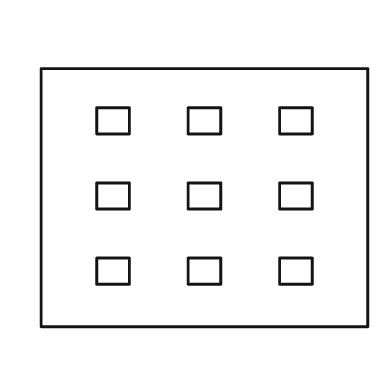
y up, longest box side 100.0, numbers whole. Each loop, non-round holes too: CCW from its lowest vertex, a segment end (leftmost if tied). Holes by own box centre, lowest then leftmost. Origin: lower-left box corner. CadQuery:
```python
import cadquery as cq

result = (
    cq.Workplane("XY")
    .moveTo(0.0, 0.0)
    .lineTo(100.0, 0.0)
    .lineTo(100.0, 79.0)
    .lineTo(0.0, 79.0)
    .close()
    .moveTo(17.0, 13.0)
    .lineTo(27.0, 13.0)
    .lineTo(27.0, 21.0)
    .lineTo(17.0, 21.0)
    .close()
    .moveTo(45.0, 13.0)
    .lineTo(55.0, 13.0)
    .lineTo(55.0, 21.0)
    .lineTo(45.0, 21.0)
    .close()
    .moveTo(73.0, 13.0)
    .lineTo(83.0, 13.0)
    .lineTo(83.0, 21.0)
    .lineTo(73.0, 21.0)
    .close()
    .moveTo(17.0, 36.0)
    .lineTo(27.0, 36.0)
    .lineTo(27.0, 44.0)
    .lineTo(17.0, 44.0)
    .close()
    .moveTo(45.0, 36.0)
    .lineTo(55.0, 36.0)
    .lineTo(55.0, 44.0)
    .lineTo(45.0, 44.0)
    .close()
    .moveTo(73.0, 36.0)
    .lineTo(83.0, 36.0)
    .lineTo(83.0, 44.0)
    .lineTo(73.0, 44.0)
    .close()
    .moveTo(17.0, 59.0)
    .lineTo(27.0, 59.0)
    .lineTo(27.0, 67.0)
    .lineTo(17.0, 67.0)
    .close()
    .moveTo(45.0, 59.0)
    .lineTo(55.0, 59.0)
    .lineTo(55.0, 67.0)
    .lineTo(45.0, 67.0)
    .close()
    .moveTo(73.0, 59.0)
    .lineTo(83.0, 59.0)
    .lineTo(83.0, 67.0)
    .lineTo(73.0, 67.0)
    .close()
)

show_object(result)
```